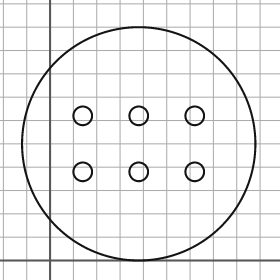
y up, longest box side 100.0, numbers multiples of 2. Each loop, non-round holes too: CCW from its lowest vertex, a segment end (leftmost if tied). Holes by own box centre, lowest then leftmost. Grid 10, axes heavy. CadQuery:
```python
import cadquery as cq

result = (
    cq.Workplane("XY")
    .moveTo(38.0, 50.0)
    .circle(50.0)
    .moveTo(14.0, 38.0)
    .circle(4.0)
    .moveTo(38.0, 38.0)
    .circle(4.0)
    .moveTo(62.0, 38.0)
    .circle(4.0)
    .moveTo(14.0, 62.0)
    .circle(4.0)
    .moveTo(38.0, 62.0)
    .circle(4.0)
    .moveTo(62.0, 62.0)
    .circle(4.0)
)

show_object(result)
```